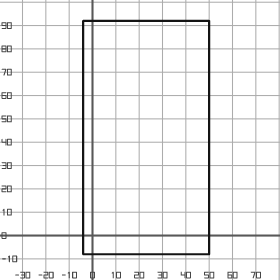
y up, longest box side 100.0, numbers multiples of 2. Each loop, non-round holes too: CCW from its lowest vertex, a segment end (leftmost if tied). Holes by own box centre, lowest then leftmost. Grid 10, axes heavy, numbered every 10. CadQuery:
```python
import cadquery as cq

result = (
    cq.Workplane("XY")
    .moveTo(-4.0, -8.0)
    .lineTo(50.0, -8.0)
    .lineTo(50.0, 92.0)
    .lineTo(-4.0, 92.0)
    .close()
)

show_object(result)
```